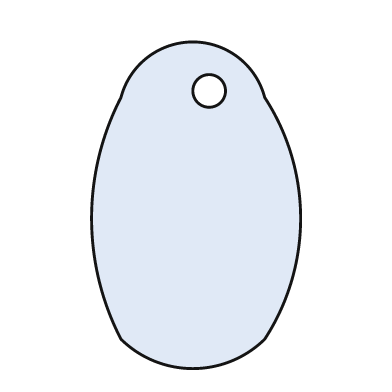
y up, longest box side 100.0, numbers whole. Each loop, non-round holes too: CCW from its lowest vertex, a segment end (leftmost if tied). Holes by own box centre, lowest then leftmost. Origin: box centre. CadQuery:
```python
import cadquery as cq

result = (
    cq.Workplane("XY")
    .moveTo(-23.0, -41.0)
    .threePointArc((-1.0, -50.0), (21.0, -41.0))
    .threePointArc((32.0, -4.0), (21.0, 33.0))
    .threePointArc((-1.0, 50.0), (-23.0, 33.0))
    .threePointArc((-32.0, -4.0), (-23.0, -41.0))
    .close()
    .moveTo(4.0, 35.0)
    .circle(5.0)
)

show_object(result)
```